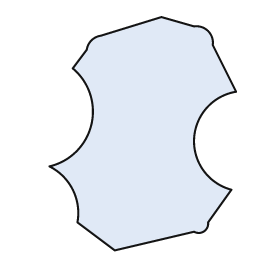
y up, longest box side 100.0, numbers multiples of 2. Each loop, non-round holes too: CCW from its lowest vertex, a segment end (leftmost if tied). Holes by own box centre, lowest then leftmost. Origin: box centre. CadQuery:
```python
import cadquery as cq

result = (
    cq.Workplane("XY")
    .moveTo(-12.0, -50.0)
    .lineTo(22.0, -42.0)
    .threePointArc((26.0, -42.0), (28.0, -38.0))
    .lineTo(38.0, -24.0)
    .threePointArc((22.0, -2.0), (40.0, 18.0))
    .lineTo(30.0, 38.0)
    .threePointArc((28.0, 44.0), (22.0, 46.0))
    .lineTo(8.0, 50.0)
    .lineTo(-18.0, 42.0)
    .threePointArc((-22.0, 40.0), (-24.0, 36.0))
    .lineTo(-30.0, 28.0)
    .threePointArc((-22.0, 4.0), (-40.0, -14.0))
    .threePointArc((-30.0, -24.0), (-28.0, -38.0))
    .close()
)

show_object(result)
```